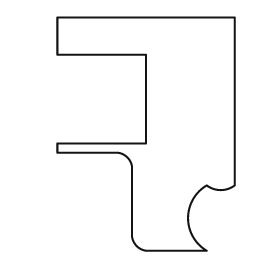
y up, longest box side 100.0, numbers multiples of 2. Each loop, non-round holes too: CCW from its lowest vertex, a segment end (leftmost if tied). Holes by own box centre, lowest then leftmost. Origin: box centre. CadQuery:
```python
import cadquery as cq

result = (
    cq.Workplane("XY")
    .moveTo(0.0, -50.0)
    .lineTo(26.0, -50.0)
    .threePointArc((18.0, -36.0), (26.0, -22.0))
    .threePointArc((32.0, -24.0), (38.0, -22.0))
    .lineTo(38.0, 50.0)
    .lineTo(-38.0, 50.0)
    .lineTo(-38.0, 34.0)
    .lineTo(0.0, 34.0)
    .lineTo(0.0, -4.0)
    .lineTo(-38.0, -4.0)
    .lineTo(-38.0, -8.0)
    .lineTo(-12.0, -8.0)
    .threePointArc((-8.0, -10.0), (-6.0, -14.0))
    .lineTo(-6.0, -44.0)
    .threePointArc((-4.0, -48.0), (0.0, -50.0))
    .close()
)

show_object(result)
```